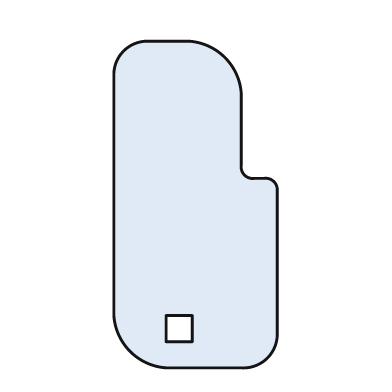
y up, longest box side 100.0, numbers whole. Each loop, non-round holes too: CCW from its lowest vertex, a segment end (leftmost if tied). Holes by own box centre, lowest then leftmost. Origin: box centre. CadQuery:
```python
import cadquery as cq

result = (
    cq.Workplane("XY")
    .moveTo(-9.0, -50.0)
    .lineTo(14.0, -50.0)
    .threePointArc((22.0, -47.0), (25.0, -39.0))
    .lineTo(25.0, 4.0)
    .threePointArc((24.0, 7.0), (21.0, 8.0))
    .lineTo(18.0, 8.0)
    .threePointArc((15.0, 9.0), (14.0, 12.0))
    .lineTo(14.0, 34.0)
    .threePointArc((9.0, 45.0), (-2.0, 50.0))
    .lineTo(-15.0, 50.0)
    .threePointArc((-22.0, 47.0), (-25.0, 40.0))
    .lineTo(-25.0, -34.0)
    .threePointArc((-20.0, -45.0), (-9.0, -50.0))
    .close()
    .moveTo(-9.0, -42.0)
    .lineTo(-1.0, -42.0)
    .lineTo(-1.0, -34.0)
    .lineTo(-9.0, -34.0)
    .close()
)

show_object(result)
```